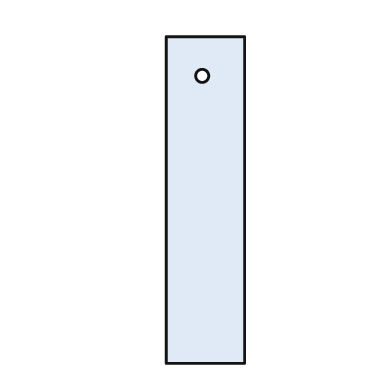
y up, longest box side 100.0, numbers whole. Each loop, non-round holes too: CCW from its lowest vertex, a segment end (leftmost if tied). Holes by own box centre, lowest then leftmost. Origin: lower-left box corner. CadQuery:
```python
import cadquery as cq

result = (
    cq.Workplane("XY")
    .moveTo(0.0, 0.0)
    .lineTo(24.0, 0.0)
    .lineTo(24.0, 100.0)
    .lineTo(0.0, 100.0)
    .close()
    .moveTo(11.0, 88.0)
    .circle(2.0)
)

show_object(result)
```